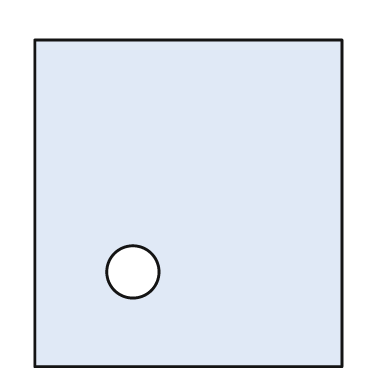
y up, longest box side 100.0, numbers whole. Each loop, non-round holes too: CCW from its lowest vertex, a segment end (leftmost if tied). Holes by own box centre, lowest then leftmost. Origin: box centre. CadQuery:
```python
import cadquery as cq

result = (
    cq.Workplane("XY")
    .moveTo(-47.0, -50.0)
    .lineTo(47.0, -50.0)
    .lineTo(47.0, 50.0)
    .lineTo(-47.0, 50.0)
    .close()
    .moveTo(-17.0, -21.0)
    .circle(8.0)
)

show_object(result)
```